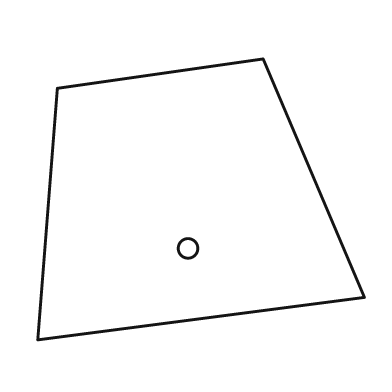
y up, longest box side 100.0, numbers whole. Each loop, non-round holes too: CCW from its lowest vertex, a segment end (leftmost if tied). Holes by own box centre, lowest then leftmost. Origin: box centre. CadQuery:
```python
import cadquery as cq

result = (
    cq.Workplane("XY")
    .moveTo(-50.0, -43.0)
    .lineTo(50.0, -30.0)
    .lineTo(19.0, 43.0)
    .lineTo(-44.0, 34.0)
    .close()
    .moveTo(-4.0, -15.0)
    .circle(3.0)
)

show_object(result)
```